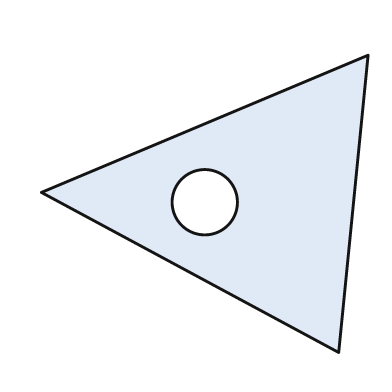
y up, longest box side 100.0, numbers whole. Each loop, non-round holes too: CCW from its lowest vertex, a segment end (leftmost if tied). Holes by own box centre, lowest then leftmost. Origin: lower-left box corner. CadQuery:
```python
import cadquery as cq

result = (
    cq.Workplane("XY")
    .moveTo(91.0, 0.0)
    .lineTo(100.0, 91.0)
    .lineTo(0.0, 49.0)
    .close()
    .moveTo(50.0, 46.0)
    .circle(10.0)
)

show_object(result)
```